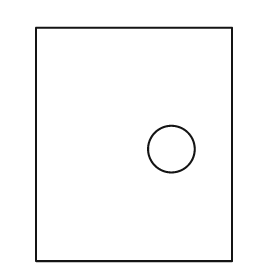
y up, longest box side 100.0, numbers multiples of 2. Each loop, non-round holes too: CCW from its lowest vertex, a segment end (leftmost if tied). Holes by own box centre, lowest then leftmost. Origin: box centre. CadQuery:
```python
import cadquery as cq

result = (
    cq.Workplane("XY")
    .moveTo(-42.0, -50.0)
    .lineTo(42.0, -50.0)
    .lineTo(42.0, 50.0)
    .lineTo(-42.0, 50.0)
    .close()
    .moveTo(16.0, -2.0)
    .circle(10.0)
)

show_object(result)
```